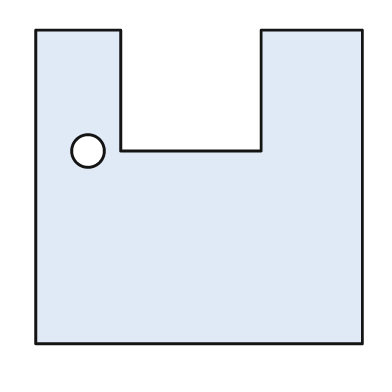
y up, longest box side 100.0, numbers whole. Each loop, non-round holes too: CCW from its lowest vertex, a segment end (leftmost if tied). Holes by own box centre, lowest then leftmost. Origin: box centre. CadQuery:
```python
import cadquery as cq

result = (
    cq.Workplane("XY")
    .moveTo(-50.0, -48.0)
    .lineTo(50.0, -48.0)
    .lineTo(50.0, 48.0)
    .lineTo(19.0, 48.0)
    .lineTo(19.0, 11.0)
    .lineTo(-24.0, 11.0)
    .lineTo(-24.0, 48.0)
    .lineTo(-50.0, 48.0)
    .close()
    .moveTo(-34.0, 11.0)
    .circle(5.0)
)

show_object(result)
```